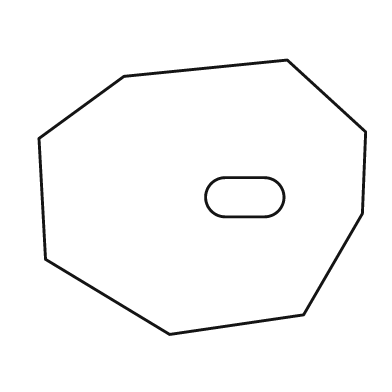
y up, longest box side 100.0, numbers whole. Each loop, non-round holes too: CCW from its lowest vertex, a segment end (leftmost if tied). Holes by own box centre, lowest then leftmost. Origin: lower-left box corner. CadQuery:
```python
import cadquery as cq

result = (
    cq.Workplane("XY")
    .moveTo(40.0, 0.0)
    .lineTo(81.0, 6.0)
    .lineTo(99.0, 37.0)
    .lineTo(100.0, 62.0)
    .lineTo(76.0, 84.0)
    .lineTo(26.0, 79.0)
    .lineTo(0.0, 60.0)
    .lineTo(2.0, 23.0)
    .close()
    .moveTo(57.0, 36.0)
    .lineTo(69.0, 36.0)
    .threePointArc((75.0, 42.0), (69.0, 48.0))
    .lineTo(57.0, 48.0)
    .threePointArc((51.0, 42.0), (57.0, 36.0))
    .close()
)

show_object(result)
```